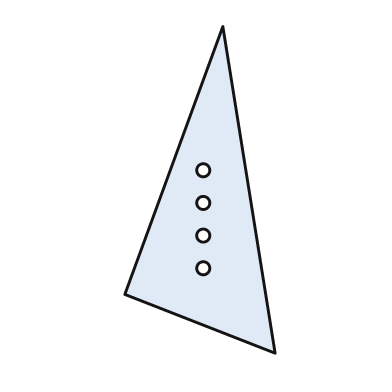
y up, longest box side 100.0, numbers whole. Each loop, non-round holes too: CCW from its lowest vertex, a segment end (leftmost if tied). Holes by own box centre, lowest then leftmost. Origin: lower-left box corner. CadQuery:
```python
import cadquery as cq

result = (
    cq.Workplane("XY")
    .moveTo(46.0, 0.0)
    .lineTo(30.0, 100.0)
    .lineTo(0.0, 18.0)
    .close()
    .moveTo(24.0, 26.0)
    .circle(2.0)
    .moveTo(24.0, 36.0)
    .circle(2.0)
    .moveTo(24.0, 46.0)
    .circle(2.0)
    .moveTo(24.0, 56.0)
    .circle(2.0)
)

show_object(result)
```